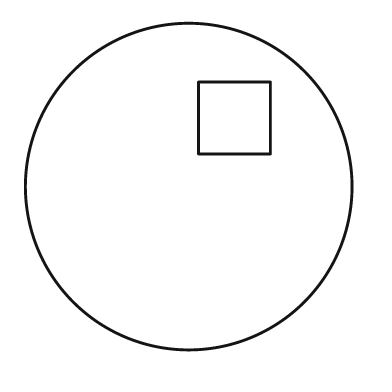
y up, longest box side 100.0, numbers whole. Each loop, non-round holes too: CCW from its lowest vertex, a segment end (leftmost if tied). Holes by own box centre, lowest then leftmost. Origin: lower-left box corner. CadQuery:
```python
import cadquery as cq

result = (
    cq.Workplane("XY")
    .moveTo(50.0, 50.0)
    .circle(50.0)
    .moveTo(53.0, 60.0)
    .lineTo(75.0, 60.0)
    .lineTo(75.0, 82.0)
    .lineTo(53.0, 82.0)
    .close()
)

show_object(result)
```